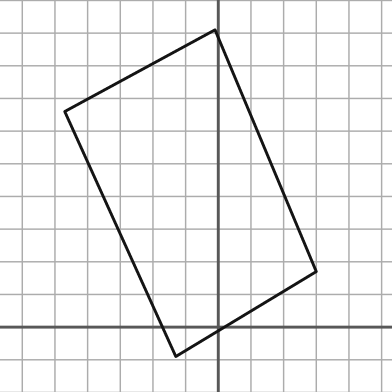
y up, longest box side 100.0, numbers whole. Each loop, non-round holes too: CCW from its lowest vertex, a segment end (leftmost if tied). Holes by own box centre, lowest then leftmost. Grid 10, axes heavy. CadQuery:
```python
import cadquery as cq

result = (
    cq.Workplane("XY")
    .moveTo(-13.0, -9.0)
    .lineTo(30.0, 17.0)
    .lineTo(-1.0, 91.0)
    .lineTo(-47.0, 66.0)
    .close()
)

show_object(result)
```